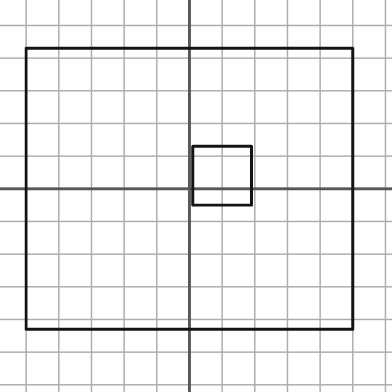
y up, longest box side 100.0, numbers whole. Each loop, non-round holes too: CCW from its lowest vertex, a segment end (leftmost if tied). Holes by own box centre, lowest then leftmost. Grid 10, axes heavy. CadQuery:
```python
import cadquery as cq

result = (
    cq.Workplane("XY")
    .moveTo(-50.0, -43.0)
    .lineTo(50.0, -43.0)
    .lineTo(50.0, 43.0)
    .lineTo(-50.0, 43.0)
    .close()
    .moveTo(1.0, -5.0)
    .lineTo(19.0, -5.0)
    .lineTo(19.0, 13.0)
    .lineTo(1.0, 13.0)
    .close()
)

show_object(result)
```